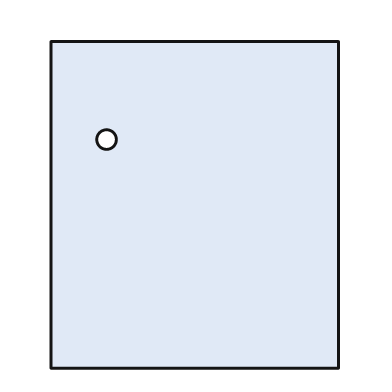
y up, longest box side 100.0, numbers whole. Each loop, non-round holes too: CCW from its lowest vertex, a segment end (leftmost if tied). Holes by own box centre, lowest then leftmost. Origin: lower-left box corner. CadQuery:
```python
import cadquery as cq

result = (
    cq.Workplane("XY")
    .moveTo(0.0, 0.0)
    .lineTo(88.0, 0.0)
    .lineTo(88.0, 100.0)
    .lineTo(0.0, 100.0)
    .close()
    .moveTo(17.0, 70.0)
    .circle(3.0)
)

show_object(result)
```